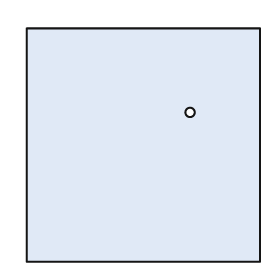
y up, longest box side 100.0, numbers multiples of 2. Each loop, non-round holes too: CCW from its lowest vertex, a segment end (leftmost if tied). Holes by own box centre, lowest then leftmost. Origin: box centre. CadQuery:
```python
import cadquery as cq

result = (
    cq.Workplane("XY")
    .moveTo(-50.0, -50.0)
    .lineTo(50.0, -50.0)
    .lineTo(50.0, 50.0)
    .lineTo(-50.0, 50.0)
    .close()
    .moveTo(20.0, 14.0)
    .circle(2.0)
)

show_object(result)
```